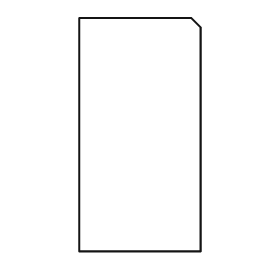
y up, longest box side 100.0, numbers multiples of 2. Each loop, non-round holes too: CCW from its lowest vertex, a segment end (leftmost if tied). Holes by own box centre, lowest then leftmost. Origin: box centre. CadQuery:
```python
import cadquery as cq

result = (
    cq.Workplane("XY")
    .moveTo(-26.0, -50.0)
    .lineTo(26.0, -50.0)
    .lineTo(26.0, 46.0)
    .lineTo(22.0, 50.0)
    .lineTo(-26.0, 50.0)
    .close()
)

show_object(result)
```